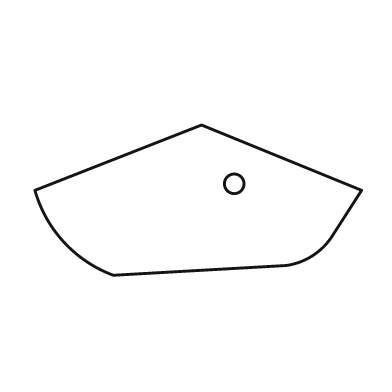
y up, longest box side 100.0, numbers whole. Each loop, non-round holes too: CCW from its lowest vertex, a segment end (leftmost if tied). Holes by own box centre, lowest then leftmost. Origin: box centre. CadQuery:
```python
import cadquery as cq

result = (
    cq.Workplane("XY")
    .moveTo(-26.0, -23.0)
    .lineTo(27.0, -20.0)
    .threePointArc((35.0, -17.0), (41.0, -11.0))
    .lineTo(50.0, 3.0)
    .lineTo(1.0, 23.0)
    .lineTo(-50.0, 3.0)
    .threePointArc((-41.0, -13.0), (-26.0, -23.0))
    .close()
    .moveTo(11.0, 5.0)
    .circle(3.0)
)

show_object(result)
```